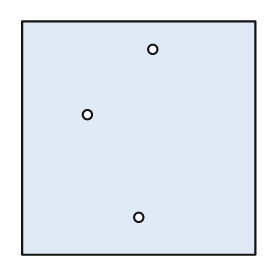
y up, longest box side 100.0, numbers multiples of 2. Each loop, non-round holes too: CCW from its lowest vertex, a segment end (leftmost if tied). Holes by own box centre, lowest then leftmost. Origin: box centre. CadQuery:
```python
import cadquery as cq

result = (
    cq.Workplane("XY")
    .moveTo(-50.0, -50.0)
    .lineTo(50.0, -50.0)
    .lineTo(50.0, 50.0)
    .lineTo(-50.0, 50.0)
    .close()
    .moveTo(0.0, -34.0)
    .circle(2.0)
    .moveTo(-22.0, 10.0)
    .circle(2.0)
    .moveTo(6.0, 38.0)
    .circle(2.0)
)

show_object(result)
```